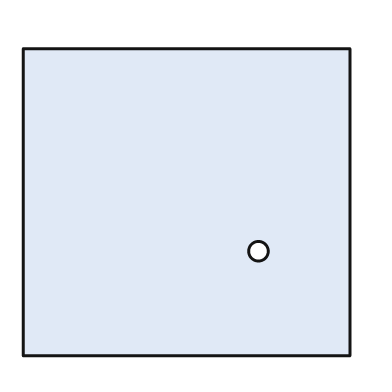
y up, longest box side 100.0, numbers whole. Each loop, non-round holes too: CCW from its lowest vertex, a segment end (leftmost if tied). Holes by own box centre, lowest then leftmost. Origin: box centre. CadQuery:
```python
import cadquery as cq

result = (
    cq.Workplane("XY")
    .moveTo(-50.0, -47.0)
    .lineTo(50.0, -47.0)
    .lineTo(50.0, 47.0)
    .lineTo(-50.0, 47.0)
    .close()
    .moveTo(22.0, -15.0)
    .circle(3.0)
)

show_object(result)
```